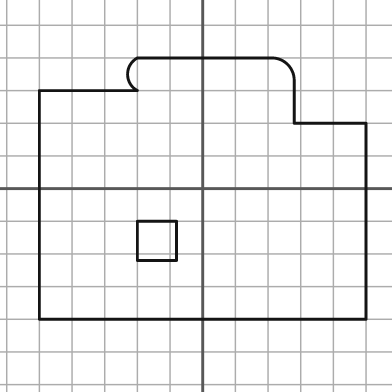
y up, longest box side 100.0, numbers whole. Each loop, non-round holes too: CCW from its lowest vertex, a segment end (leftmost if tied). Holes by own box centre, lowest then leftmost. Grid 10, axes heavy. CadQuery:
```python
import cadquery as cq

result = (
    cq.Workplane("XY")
    .moveTo(-50.0, -40.0)
    .lineTo(50.0, -40.0)
    .lineTo(50.0, 20.0)
    .lineTo(28.0, 20.0)
    .lineTo(28.0, 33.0)
    .threePointArc((26.0, 38.0), (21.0, 40.0))
    .lineTo(-20.0, 40.0)
    .threePointArc((-23.0, 35.0), (-20.0, 30.0))
    .lineTo(-50.0, 30.0)
    .close()
    .moveTo(-20.0, -22.0)
    .lineTo(-8.0, -22.0)
    .lineTo(-8.0, -10.0)
    .lineTo(-20.0, -10.0)
    .close()
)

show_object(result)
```